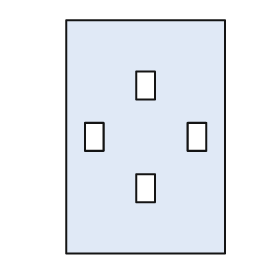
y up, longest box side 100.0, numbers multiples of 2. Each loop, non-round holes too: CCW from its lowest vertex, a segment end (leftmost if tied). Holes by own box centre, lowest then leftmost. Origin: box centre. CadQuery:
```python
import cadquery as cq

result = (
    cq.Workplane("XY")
    .moveTo(-34.0, -50.0)
    .lineTo(34.0, -50.0)
    .lineTo(34.0, 50.0)
    .lineTo(-34.0, 50.0)
    .close()
    .moveTo(-4.0, -28.0)
    .lineTo(4.0, -28.0)
    .lineTo(4.0, -16.0)
    .lineTo(-4.0, -16.0)
    .close()
    .moveTo(-26.0, -6.0)
    .lineTo(-18.0, -6.0)
    .lineTo(-18.0, 6.0)
    .lineTo(-26.0, 6.0)
    .close()
    .moveTo(18.0, -6.0)
    .lineTo(26.0, -6.0)
    .lineTo(26.0, 6.0)
    .lineTo(18.0, 6.0)
    .close()
    .moveTo(-4.0, 16.0)
    .lineTo(4.0, 16.0)
    .lineTo(4.0, 28.0)
    .lineTo(-4.0, 28.0)
    .close()
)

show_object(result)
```